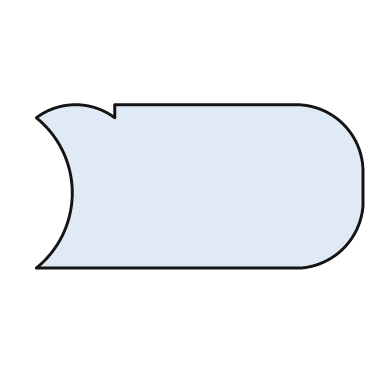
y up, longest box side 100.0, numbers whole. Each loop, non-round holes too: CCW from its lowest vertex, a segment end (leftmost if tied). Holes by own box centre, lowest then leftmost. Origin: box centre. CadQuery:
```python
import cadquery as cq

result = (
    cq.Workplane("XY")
    .moveTo(-50.0, -25.0)
    .lineTo(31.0, -25.0)
    .threePointArc((44.0, -19.0), (50.0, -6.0))
    .lineTo(50.0, 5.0)
    .threePointArc((44.0, 19.0), (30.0, 25.0))
    .lineTo(-26.0, 25.0)
    .lineTo(-26.0, 21.0)
    .threePointArc((-38.0, 25.0), (-50.0, 21.0))
    .threePointArc((-39.0, -2.0), (-50.0, -25.0))
    .close()
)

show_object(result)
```